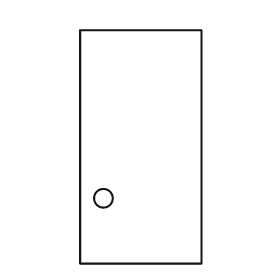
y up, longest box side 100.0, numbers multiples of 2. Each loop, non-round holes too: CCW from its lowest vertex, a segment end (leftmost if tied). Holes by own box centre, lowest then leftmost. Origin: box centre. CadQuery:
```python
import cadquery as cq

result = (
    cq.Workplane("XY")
    .moveTo(-26.0, -50.0)
    .lineTo(26.0, -50.0)
    .lineTo(26.0, 50.0)
    .lineTo(-26.0, 50.0)
    .close()
    .moveTo(-16.0, -22.0)
    .circle(4.0)
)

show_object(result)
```